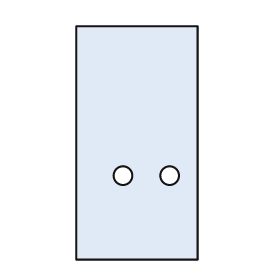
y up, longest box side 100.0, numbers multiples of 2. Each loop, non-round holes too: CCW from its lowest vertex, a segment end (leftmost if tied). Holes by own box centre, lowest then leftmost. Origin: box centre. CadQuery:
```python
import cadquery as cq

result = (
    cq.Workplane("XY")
    .moveTo(-26.0, -50.0)
    .lineTo(26.0, -50.0)
    .lineTo(26.0, 50.0)
    .lineTo(-26.0, 50.0)
    .close()
    .moveTo(-6.0, -14.0)
    .circle(4.0)
    .moveTo(14.0, -14.0)
    .circle(4.0)
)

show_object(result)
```